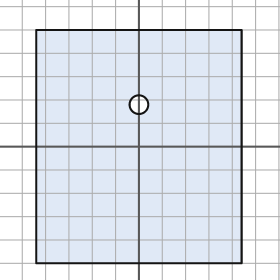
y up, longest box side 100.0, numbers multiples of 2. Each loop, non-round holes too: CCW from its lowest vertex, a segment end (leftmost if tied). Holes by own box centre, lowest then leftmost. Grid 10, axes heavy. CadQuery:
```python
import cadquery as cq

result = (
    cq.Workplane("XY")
    .moveTo(-44.0, -50.0)
    .lineTo(44.0, -50.0)
    .lineTo(44.0, 50.0)
    .lineTo(-44.0, 50.0)
    .close()
    .moveTo(0.0, 18.0)
    .circle(4.0)
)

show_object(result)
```